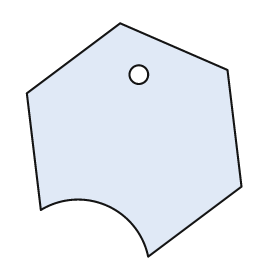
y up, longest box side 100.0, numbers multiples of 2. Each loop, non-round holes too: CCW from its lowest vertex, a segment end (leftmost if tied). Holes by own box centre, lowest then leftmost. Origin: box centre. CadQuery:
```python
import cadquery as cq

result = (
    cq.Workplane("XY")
    .moveTo(6.0, -50.0)
    .lineTo(46.0, -20.0)
    .lineTo(40.0, 30.0)
    .lineTo(-6.0, 50.0)
    .lineTo(-46.0, 20.0)
    .lineTo(-40.0, -30.0)
    .threePointArc((-12.0, -28.0), (6.0, -50.0))
    .close()
    .moveTo(2.0, 28.0)
    .circle(4.0)
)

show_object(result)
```